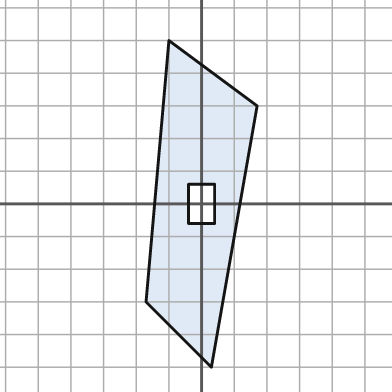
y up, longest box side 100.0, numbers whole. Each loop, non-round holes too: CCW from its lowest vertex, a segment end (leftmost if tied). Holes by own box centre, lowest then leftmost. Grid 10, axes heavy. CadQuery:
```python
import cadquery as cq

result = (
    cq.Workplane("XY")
    .moveTo(3.0, -50.0)
    .lineTo(17.0, 30.0)
    .lineTo(-10.0, 50.0)
    .lineTo(-17.0, -30.0)
    .close()
    .moveTo(-4.0, -6.0)
    .lineTo(4.0, -6.0)
    .lineTo(4.0, 6.0)
    .lineTo(-4.0, 6.0)
    .close()
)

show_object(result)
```